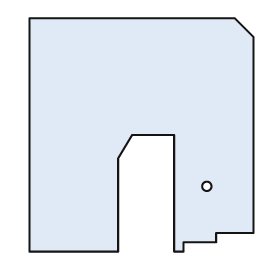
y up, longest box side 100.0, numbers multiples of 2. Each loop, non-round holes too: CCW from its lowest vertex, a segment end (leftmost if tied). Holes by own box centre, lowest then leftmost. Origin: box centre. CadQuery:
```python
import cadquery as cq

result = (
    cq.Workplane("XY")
    .moveTo(-48.0, -50.0)
    .lineTo(-10.0, -50.0)
    .lineTo(-10.0, -10.0)
    .lineTo(-4.0, 0.0)
    .lineTo(14.0, 0.0)
    .lineTo(14.0, -50.0)
    .lineTo(18.0, -50.0)
    .lineTo(18.0, -46.0)
    .lineTo(32.0, -46.0)
    .lineTo(32.0, -42.0)
    .lineTo(48.0, -42.0)
    .lineTo(48.0, 42.0)
    .lineTo(40.0, 50.0)
    .lineTo(-48.0, 50.0)
    .close()
    .moveTo(28.0, -22.0)
    .circle(2.0)
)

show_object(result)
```